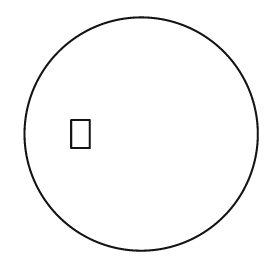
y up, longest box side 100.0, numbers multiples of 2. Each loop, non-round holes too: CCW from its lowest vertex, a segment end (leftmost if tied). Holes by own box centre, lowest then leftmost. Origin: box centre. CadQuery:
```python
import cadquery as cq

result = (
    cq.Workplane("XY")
    .moveTo(0.0, 0.0)
    .circle(50.0)
    .moveTo(-30.0, -6.0)
    .lineTo(-22.0, -6.0)
    .lineTo(-22.0, 6.0)
    .lineTo(-30.0, 6.0)
    .close()
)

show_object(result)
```